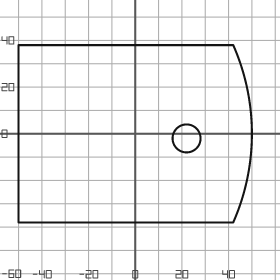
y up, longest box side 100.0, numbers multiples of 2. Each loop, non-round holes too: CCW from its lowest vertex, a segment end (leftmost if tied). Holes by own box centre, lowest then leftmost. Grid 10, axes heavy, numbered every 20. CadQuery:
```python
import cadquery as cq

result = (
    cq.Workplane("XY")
    .moveTo(-50.0, -38.0)
    .lineTo(42.0, -38.0)
    .threePointArc((50.0, 0.0), (42.0, 38.0))
    .lineTo(-50.0, 38.0)
    .close()
    .moveTo(22.0, -2.0)
    .circle(6.0)
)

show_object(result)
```